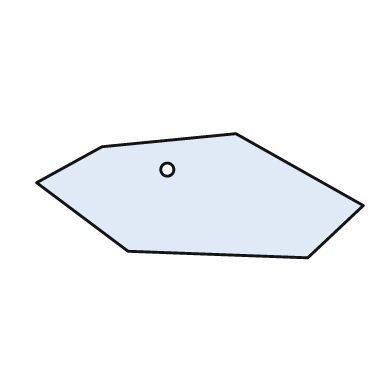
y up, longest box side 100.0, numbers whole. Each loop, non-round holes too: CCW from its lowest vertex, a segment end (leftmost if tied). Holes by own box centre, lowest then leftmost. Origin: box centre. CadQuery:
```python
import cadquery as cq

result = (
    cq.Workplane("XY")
    .moveTo(33.0, -19.0)
    .lineTo(50.0, -3.0)
    .lineTo(11.0, 19.0)
    .lineTo(-30.0, 15.0)
    .lineTo(-50.0, 4.0)
    .lineTo(-22.0, -17.0)
    .close()
    .moveTo(-10.0, 8.0)
    .circle(2.0)
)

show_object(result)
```